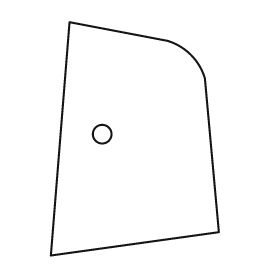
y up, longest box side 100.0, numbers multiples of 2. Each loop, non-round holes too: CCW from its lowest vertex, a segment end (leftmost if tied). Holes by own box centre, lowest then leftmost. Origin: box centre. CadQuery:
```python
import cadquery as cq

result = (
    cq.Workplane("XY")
    .moveTo(-36.0, -50.0)
    .lineTo(36.0, -40.0)
    .lineTo(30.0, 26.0)
    .threePointArc((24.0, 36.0), (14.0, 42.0))
    .lineTo(-28.0, 50.0)
    .close()
    .moveTo(-14.0, 2.0)
    .circle(4.0)
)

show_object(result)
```